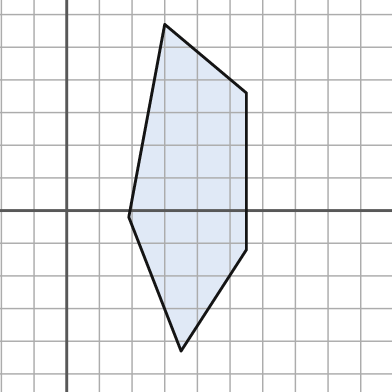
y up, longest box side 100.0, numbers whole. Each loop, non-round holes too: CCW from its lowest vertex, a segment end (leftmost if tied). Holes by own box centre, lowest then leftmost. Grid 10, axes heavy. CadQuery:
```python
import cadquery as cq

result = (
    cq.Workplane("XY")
    .moveTo(35.0, -43.0)
    .lineTo(55.0, -12.0)
    .lineTo(55.0, 36.0)
    .lineTo(30.0, 57.0)
    .lineTo(19.0, -2.0)
    .close()
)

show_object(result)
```